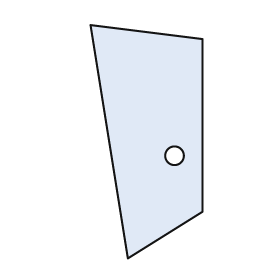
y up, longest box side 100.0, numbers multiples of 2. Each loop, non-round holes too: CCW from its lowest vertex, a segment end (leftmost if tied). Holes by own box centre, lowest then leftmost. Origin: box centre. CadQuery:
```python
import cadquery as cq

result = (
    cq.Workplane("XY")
    .moveTo(-8.0, -50.0)
    .lineTo(24.0, -30.0)
    .lineTo(24.0, 44.0)
    .lineTo(-24.0, 50.0)
    .close()
    .moveTo(12.0, -6.0)
    .circle(4.0)
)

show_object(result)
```